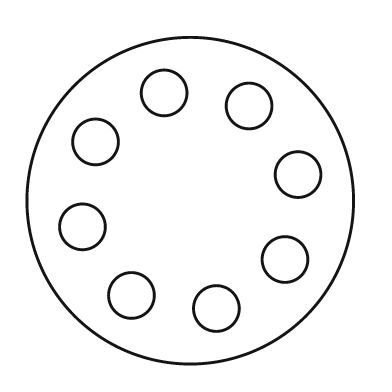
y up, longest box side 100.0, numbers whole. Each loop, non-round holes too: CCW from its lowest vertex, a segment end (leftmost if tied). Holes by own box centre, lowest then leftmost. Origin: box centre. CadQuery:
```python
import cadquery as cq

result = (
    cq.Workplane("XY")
    .moveTo(0.0, 0.0)
    .circle(50.0)
    .moveTo(8.0, -33.0)
    .circle(7.0)
    .moveTo(-18.0, -29.0)
    .circle(7.0)
    .moveTo(29.0, -18.0)
    .circle(7.0)
    .moveTo(-33.0, -8.0)
    .circle(7.0)
    .moveTo(33.0, 8.0)
    .circle(7.0)
    .moveTo(-29.0, 18.0)
    .circle(7.0)
    .moveTo(18.0, 29.0)
    .circle(7.0)
    .moveTo(-8.0, 33.0)
    .circle(7.0)
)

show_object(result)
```